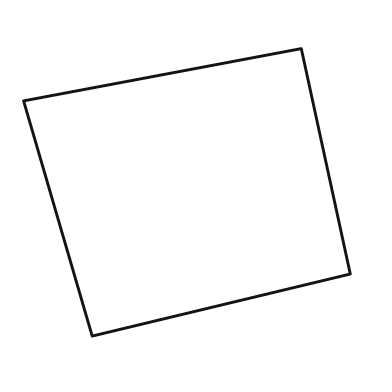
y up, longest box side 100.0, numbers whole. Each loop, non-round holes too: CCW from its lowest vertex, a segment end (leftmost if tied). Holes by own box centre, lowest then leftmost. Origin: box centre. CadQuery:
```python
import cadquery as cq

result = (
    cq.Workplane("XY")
    .moveTo(-29.0, -44.0)
    .lineTo(50.0, -25.0)
    .lineTo(35.0, 44.0)
    .lineTo(-50.0, 28.0)
    .close()
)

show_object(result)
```